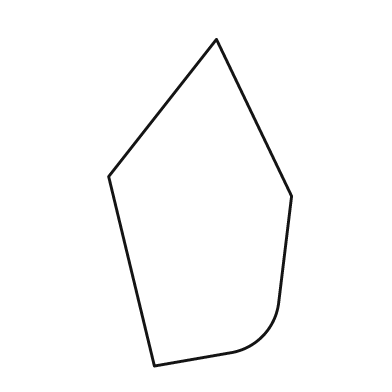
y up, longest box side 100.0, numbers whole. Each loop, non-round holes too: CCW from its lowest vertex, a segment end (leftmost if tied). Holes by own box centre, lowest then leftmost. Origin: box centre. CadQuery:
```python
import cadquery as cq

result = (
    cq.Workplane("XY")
    .moveTo(-14.0, -50.0)
    .lineTo(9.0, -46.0)
    .threePointArc((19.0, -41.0), (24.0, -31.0))
    .lineTo(28.0, 2.0)
    .lineTo(5.0, 50.0)
    .lineTo(-28.0, 8.0)
    .close()
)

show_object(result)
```